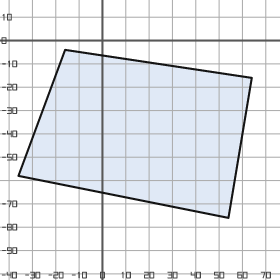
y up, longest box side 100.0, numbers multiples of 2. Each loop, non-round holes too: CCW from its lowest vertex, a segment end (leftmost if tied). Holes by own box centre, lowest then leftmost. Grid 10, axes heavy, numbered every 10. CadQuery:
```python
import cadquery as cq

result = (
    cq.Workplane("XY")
    .moveTo(54.0, -76.0)
    .lineTo(64.0, -16.0)
    .lineTo(-16.0, -4.0)
    .lineTo(-36.0, -58.0)
    .close()
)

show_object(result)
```